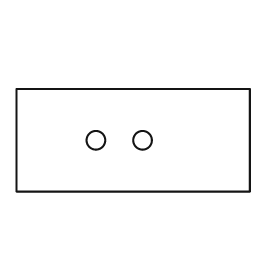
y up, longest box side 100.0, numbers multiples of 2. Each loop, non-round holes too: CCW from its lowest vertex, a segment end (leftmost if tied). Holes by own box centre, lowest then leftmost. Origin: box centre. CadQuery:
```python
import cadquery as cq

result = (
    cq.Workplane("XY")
    .moveTo(-50.0, -22.0)
    .lineTo(50.0, -22.0)
    .lineTo(50.0, 22.0)
    .lineTo(-50.0, 22.0)
    .close()
    .moveTo(-16.0, 0.0)
    .circle(4.0)
    .moveTo(4.0, 0.0)
    .circle(4.0)
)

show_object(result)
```